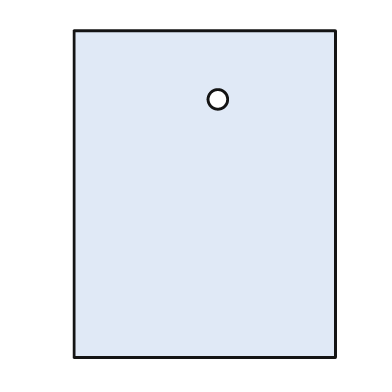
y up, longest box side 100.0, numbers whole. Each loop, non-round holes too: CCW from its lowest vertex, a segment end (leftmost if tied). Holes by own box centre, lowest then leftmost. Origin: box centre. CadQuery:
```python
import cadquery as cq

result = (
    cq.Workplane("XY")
    .moveTo(-40.0, -50.0)
    .lineTo(40.0, -50.0)
    .lineTo(40.0, 50.0)
    .lineTo(-40.0, 50.0)
    .close()
    .moveTo(4.0, 29.0)
    .circle(3.0)
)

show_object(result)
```